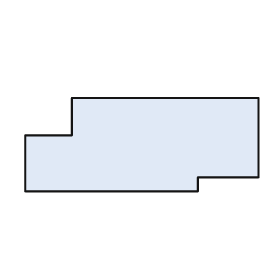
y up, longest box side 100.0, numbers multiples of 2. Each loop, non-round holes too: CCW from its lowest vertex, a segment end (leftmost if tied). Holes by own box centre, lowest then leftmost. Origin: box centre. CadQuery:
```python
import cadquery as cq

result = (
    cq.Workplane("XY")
    .moveTo(-50.0, -20.0)
    .lineTo(24.0, -20.0)
    .lineTo(24.0, -14.0)
    .lineTo(50.0, -14.0)
    .lineTo(50.0, 20.0)
    .lineTo(-30.0, 20.0)
    .lineTo(-30.0, 4.0)
    .lineTo(-50.0, 4.0)
    .close()
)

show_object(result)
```